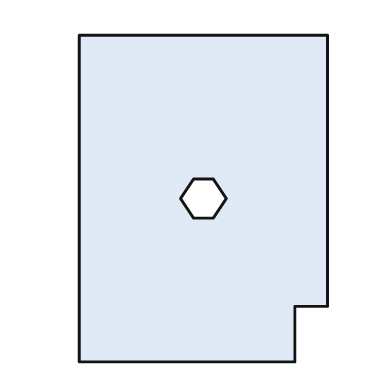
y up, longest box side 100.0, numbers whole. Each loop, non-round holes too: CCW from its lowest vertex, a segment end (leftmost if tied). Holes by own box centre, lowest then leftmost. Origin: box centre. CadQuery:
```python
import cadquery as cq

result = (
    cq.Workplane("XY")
    .moveTo(-38.0, -50.0)
    .lineTo(28.0, -50.0)
    .lineTo(28.0, -33.0)
    .lineTo(38.0, -33.0)
    .lineTo(38.0, 50.0)
    .lineTo(-38.0, 50.0)
    .close()
    .moveTo(-3.0, -6.0)
    .lineTo(3.0, -6.0)
    .lineTo(7.0, 0.0)
    .lineTo(3.0, 6.0)
    .lineTo(-3.0, 6.0)
    .lineTo(-7.0, 0.0)
    .close()
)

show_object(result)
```